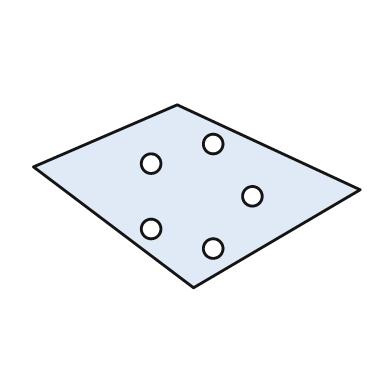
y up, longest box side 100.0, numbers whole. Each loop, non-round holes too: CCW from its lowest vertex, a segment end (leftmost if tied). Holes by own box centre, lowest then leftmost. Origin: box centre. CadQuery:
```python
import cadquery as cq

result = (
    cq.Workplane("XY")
    .moveTo(-1.0, -28.0)
    .lineTo(50.0, 2.0)
    .lineTo(-6.0, 28.0)
    .lineTo(-50.0, 9.0)
    .close()
    .moveTo(5.0, -16.0)
    .circle(3.0)
    .moveTo(-14.0, -10.0)
    .circle(3.0)
    .moveTo(17.0, 0.0)
    .circle(3.0)
    .moveTo(-14.0, 10.0)
    .circle(3.0)
    .moveTo(5.0, 16.0)
    .circle(3.0)
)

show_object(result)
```